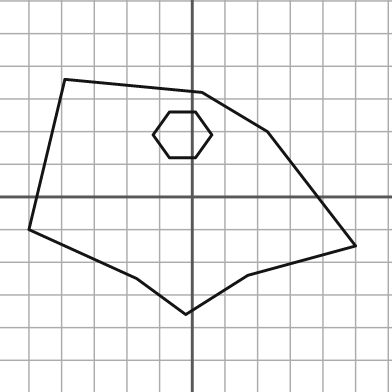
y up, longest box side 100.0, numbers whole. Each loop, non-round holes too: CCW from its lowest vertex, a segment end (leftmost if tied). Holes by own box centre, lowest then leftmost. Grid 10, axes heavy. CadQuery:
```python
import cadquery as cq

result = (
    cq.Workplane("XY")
    .moveTo(-2.0, -36.0)
    .lineTo(17.0, -24.0)
    .lineTo(50.0, -15.0)
    .lineTo(23.0, 20.0)
    .lineTo(3.0, 32.0)
    .lineTo(-39.0, 36.0)
    .lineTo(-50.0, -10.0)
    .lineTo(-17.0, -25.0)
    .close()
    .moveTo(-7.0, 12.0)
    .lineTo(1.0, 12.0)
    .lineTo(6.0, 19.0)
    .lineTo(1.0, 26.0)
    .lineTo(-7.0, 26.0)
    .lineTo(-12.0, 19.0)
    .close()
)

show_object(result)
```